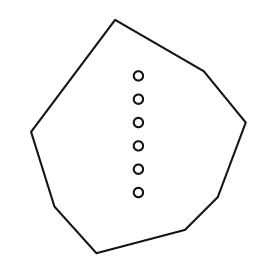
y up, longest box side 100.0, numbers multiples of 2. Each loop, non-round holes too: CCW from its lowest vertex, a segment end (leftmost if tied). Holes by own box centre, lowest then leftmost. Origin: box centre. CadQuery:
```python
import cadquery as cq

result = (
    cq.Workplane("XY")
    .moveTo(-18.0, -50.0)
    .lineTo(20.0, -40.0)
    .lineTo(34.0, -26.0)
    .lineTo(46.0, 6.0)
    .lineTo(28.0, 28.0)
    .lineTo(-10.0, 50.0)
    .lineTo(-46.0, 2.0)
    .lineTo(-36.0, -30.0)
    .close()
    .moveTo(0.0, -24.0)
    .circle(2.0)
    .moveTo(0.0, -14.0)
    .circle(2.0)
    .moveTo(0.0, -4.0)
    .circle(2.0)
    .moveTo(0.0, 6.0)
    .circle(2.0)
    .moveTo(0.0, 16.0)
    .circle(2.0)
    .moveTo(0.0, 26.0)
    .circle(2.0)
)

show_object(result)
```